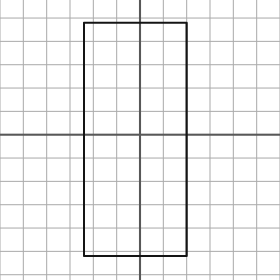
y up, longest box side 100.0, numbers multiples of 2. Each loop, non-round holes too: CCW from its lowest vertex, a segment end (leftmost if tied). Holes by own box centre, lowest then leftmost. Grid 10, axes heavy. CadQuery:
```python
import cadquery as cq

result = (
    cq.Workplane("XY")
    .moveTo(-24.0, -52.0)
    .lineTo(20.0, -52.0)
    .lineTo(20.0, 48.0)
    .lineTo(-24.0, 48.0)
    .close()
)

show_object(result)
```